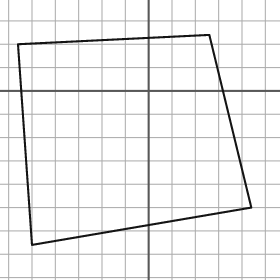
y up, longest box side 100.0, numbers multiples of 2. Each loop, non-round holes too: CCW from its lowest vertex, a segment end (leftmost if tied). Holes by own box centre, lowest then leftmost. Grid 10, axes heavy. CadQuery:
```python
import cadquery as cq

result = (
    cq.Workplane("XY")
    .moveTo(-50.0, -66.0)
    .lineTo(44.0, -50.0)
    .lineTo(26.0, 24.0)
    .lineTo(-56.0, 20.0)
    .close()
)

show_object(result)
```